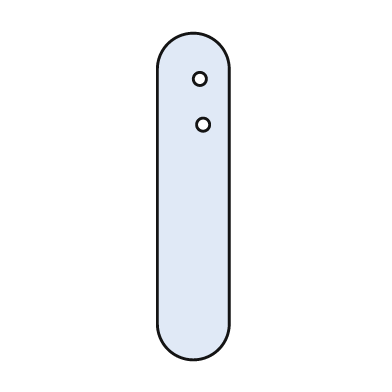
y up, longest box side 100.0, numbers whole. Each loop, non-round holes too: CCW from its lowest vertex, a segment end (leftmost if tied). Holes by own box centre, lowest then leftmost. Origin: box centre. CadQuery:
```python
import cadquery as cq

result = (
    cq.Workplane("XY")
    .moveTo(-11.0, -39.0)
    .threePointArc((0.0, -50.0), (11.0, -39.0))
    .lineTo(11.0, 39.0)
    .threePointArc((0.0, 50.0), (-11.0, 39.0))
    .close()
    .moveTo(3.0, 22.0)
    .circle(2.0)
    .moveTo(2.0, 36.0)
    .circle(2.0)
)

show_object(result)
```